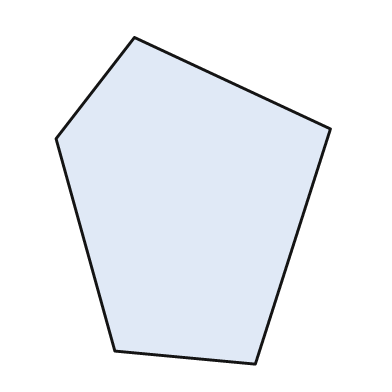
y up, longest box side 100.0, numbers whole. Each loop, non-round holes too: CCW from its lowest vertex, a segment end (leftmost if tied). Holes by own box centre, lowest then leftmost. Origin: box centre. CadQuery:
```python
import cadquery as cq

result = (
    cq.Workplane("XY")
    .moveTo(19.0, -50.0)
    .lineTo(42.0, 22.0)
    .lineTo(-18.0, 50.0)
    .lineTo(-42.0, 19.0)
    .lineTo(-24.0, -46.0)
    .close()
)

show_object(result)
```